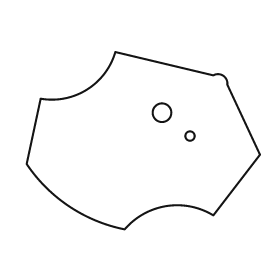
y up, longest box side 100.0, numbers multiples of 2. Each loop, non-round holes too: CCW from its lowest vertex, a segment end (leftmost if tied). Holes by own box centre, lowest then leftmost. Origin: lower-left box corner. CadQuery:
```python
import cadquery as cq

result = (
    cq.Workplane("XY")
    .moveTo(42.0, 0.0)
    .threePointArc((60.0, 10.0), (80.0, 6.0))
    .lineTo(100.0, 32.0)
    .lineTo(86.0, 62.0)
    .threePointArc((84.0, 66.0), (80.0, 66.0))
    .lineTo(38.0, 76.0)
    .threePointArc((26.0, 60.0), (6.0, 56.0))
    .lineTo(0.0, 28.0)
    .threePointArc((18.0, 10.0), (42.0, 0.0))
    .close()
    .moveTo(70.0, 40.0)
    .circle(2.0)
    .moveTo(58.0, 50.0)
    .circle(4.0)
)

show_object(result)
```